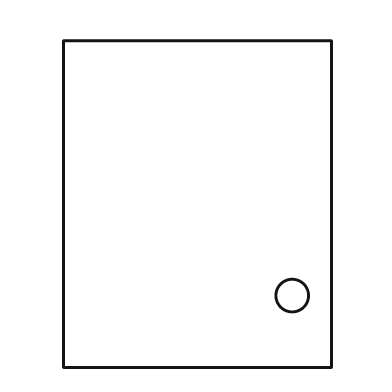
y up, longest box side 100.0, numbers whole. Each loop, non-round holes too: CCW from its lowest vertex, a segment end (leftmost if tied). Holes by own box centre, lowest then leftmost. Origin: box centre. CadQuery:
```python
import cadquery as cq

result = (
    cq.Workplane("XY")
    .moveTo(-41.0, -50.0)
    .lineTo(41.0, -50.0)
    .lineTo(41.0, 50.0)
    .lineTo(-41.0, 50.0)
    .close()
    .moveTo(29.0, -28.0)
    .circle(5.0)
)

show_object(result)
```